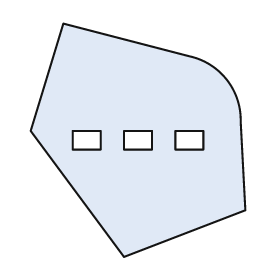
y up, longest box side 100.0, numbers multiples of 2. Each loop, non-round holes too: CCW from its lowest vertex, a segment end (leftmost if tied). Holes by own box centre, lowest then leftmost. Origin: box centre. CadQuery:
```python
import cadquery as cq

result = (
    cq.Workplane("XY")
    .moveTo(-6.0, -50.0)
    .lineTo(46.0, -30.0)
    .lineTo(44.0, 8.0)
    .threePointArc((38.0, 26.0), (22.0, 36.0))
    .lineTo(-32.0, 50.0)
    .lineTo(-46.0, 4.0)
    .close()
    .moveTo(-28.0, -4.0)
    .lineTo(-16.0, -4.0)
    .lineTo(-16.0, 4.0)
    .lineTo(-28.0, 4.0)
    .close()
    .moveTo(-6.0, -4.0)
    .lineTo(6.0, -4.0)
    .lineTo(6.0, 4.0)
    .lineTo(-6.0, 4.0)
    .close()
    .moveTo(16.0, -4.0)
    .lineTo(28.0, -4.0)
    .lineTo(28.0, 4.0)
    .lineTo(16.0, 4.0)
    .close()
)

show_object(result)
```